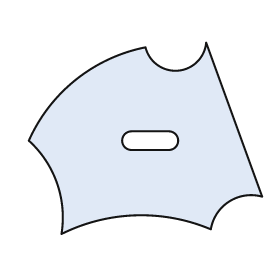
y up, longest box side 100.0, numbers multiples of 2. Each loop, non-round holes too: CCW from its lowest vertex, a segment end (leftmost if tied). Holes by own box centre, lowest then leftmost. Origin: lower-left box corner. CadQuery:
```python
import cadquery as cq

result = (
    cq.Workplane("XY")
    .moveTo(14.0, 0.0)
    .threePointArc((46.0, 8.0), (78.0, 2.0))
    .threePointArc((86.0, 14.0), (100.0, 16.0))
    .lineTo(76.0, 82.0)
    .threePointArc((64.0, 70.0), (50.0, 80.0))
    .threePointArc((20.0, 66.0), (0.0, 40.0))
    .threePointArc((12.0, 22.0), (14.0, 0.0))
    .close()
    .moveTo(44.0, 36.0)
    .lineTo(60.0, 36.0)
    .threePointArc((64.0, 40.0), (60.0, 44.0))
    .lineTo(44.0, 44.0)
    .threePointArc((40.0, 40.0), (44.0, 36.0))
    .close()
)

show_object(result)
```